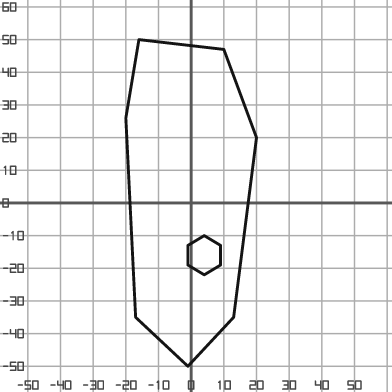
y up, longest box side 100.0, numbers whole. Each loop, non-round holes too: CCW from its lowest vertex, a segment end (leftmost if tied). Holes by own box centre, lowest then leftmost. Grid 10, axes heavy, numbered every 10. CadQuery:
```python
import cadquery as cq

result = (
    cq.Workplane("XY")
    .moveTo(-1.0, -50.0)
    .lineTo(13.0, -35.0)
    .lineTo(20.0, 20.0)
    .lineTo(10.0, 47.0)
    .lineTo(-16.0, 50.0)
    .lineTo(-20.0, 26.0)
    .lineTo(-17.0, -35.0)
    .close()
    .moveTo(4.0, -22.0)
    .lineTo(9.0, -19.0)
    .lineTo(9.0, -13.0)
    .lineTo(4.0, -10.0)
    .lineTo(-1.0, -13.0)
    .lineTo(-1.0, -19.0)
    .close()
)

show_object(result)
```